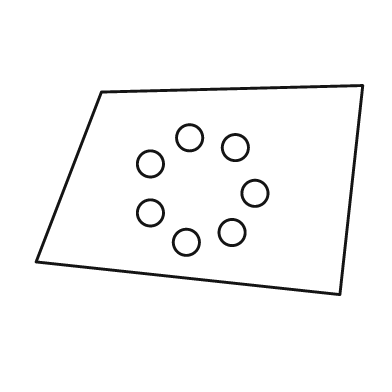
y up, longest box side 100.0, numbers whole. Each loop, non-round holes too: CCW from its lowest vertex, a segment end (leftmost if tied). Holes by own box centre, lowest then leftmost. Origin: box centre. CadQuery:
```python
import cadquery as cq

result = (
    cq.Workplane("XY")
    .moveTo(43.0, -32.0)
    .lineTo(50.0, 32.0)
    .lineTo(-30.0, 30.0)
    .lineTo(-50.0, -22.0)
    .close()
    .moveTo(-4.0, -16.0)
    .circle(4.0)
    .moveTo(10.0, -13.0)
    .circle(4.0)
    .moveTo(-15.0, -7.0)
    .circle(4.0)
    .moveTo(17.0, -1.0)
    .circle(4.0)
    .moveTo(-15.0, 8.0)
    .circle(4.0)
    .moveTo(11.0, 13.0)
    .circle(4.0)
    .moveTo(-3.0, 16.0)
    .circle(4.0)
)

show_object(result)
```